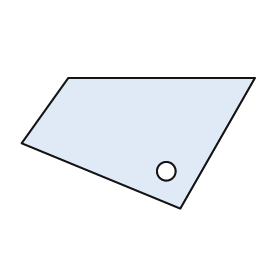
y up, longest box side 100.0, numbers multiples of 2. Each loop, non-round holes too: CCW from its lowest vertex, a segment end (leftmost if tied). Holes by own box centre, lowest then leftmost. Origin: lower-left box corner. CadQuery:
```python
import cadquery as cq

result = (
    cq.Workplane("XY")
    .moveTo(68.0, 0.0)
    .lineTo(100.0, 56.0)
    .lineTo(20.0, 56.0)
    .lineTo(0.0, 28.0)
    .close()
    .moveTo(62.0, 16.0)
    .circle(4.0)
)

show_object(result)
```